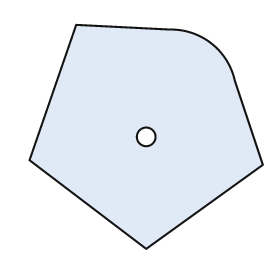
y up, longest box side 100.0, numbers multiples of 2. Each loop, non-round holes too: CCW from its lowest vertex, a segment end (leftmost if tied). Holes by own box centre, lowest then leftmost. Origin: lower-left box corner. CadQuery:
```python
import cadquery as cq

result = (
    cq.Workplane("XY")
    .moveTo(50.0, 0.0)
    .lineTo(100.0, 36.0)
    .lineTo(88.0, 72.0)
    .threePointArc((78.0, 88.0), (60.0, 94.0))
    .lineTo(20.0, 96.0)
    .lineTo(0.0, 38.0)
    .close()
    .moveTo(50.0, 48.0)
    .circle(4.0)
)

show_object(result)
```